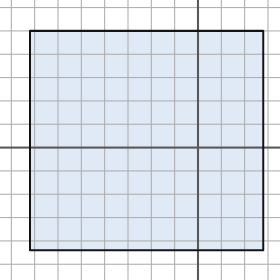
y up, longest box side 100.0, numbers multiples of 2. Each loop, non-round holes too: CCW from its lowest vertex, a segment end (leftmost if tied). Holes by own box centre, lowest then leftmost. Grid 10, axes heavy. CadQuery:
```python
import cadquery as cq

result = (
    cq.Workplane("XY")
    .moveTo(-72.0, -44.0)
    .lineTo(28.0, -44.0)
    .lineTo(28.0, 50.0)
    .lineTo(-72.0, 50.0)
    .close()
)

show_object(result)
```